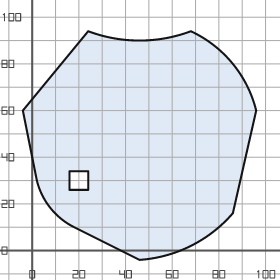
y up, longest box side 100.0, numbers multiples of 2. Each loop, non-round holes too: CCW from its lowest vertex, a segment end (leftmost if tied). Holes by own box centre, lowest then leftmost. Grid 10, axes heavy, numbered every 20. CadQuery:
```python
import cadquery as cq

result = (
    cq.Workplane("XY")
    .moveTo(46.0, -4.0)
    .threePointArc((68.0, 2.0), (86.0, 16.0))
    .lineTo(96.0, 60.0)
    .threePointArc((86.0, 80.0), (68.0, 94.0))
    .threePointArc((46.0, 90.0), (24.0, 94.0))
    .lineTo(-4.0, 60.0)
    .lineTo(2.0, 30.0)
    .threePointArc((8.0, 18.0), (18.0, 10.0))
    .close()
    .moveTo(16.0, 26.0)
    .lineTo(24.0, 26.0)
    .lineTo(24.0, 34.0)
    .lineTo(16.0, 34.0)
    .close()
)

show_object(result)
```